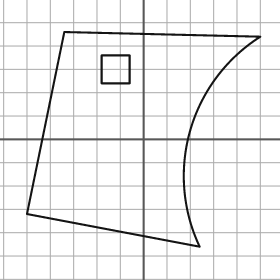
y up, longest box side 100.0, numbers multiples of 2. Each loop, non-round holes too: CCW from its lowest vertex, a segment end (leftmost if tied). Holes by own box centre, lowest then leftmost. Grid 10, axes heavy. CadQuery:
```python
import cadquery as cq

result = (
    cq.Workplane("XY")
    .moveTo(24.0, -46.0)
    .threePointArc((20.0, 4.0), (50.0, 44.0))
    .lineTo(-34.0, 46.0)
    .lineTo(-50.0, -32.0)
    .close()
    .moveTo(-18.0, 24.0)
    .lineTo(-6.0, 24.0)
    .lineTo(-6.0, 36.0)
    .lineTo(-18.0, 36.0)
    .close()
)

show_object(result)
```